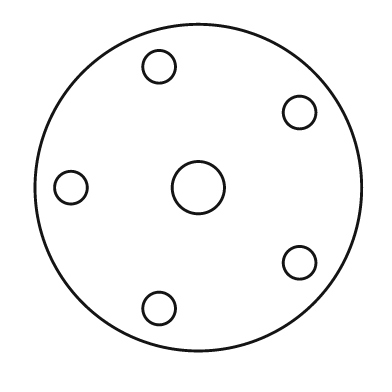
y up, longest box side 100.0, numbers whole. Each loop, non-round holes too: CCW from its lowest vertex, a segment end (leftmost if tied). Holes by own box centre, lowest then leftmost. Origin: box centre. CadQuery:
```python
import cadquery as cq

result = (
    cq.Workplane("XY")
    .moveTo(0.0, 0.0)
    .circle(50.0)
    .moveTo(-12.0, -37.0)
    .circle(5.0)
    .moveTo(31.0, -23.0)
    .circle(5.0)
    .moveTo(-39.0, 0.0)
    .circle(5.0)
    .moveTo(0.0, 0.0)
    .circle(8.0)
    .moveTo(31.0, 23.0)
    .circle(5.0)
    .moveTo(-12.0, 37.0)
    .circle(5.0)
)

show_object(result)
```